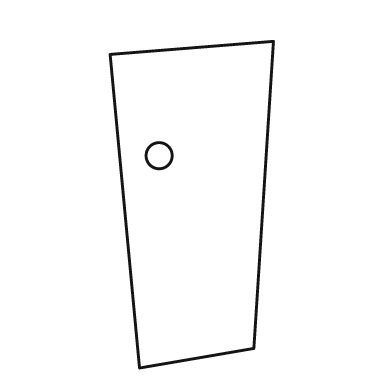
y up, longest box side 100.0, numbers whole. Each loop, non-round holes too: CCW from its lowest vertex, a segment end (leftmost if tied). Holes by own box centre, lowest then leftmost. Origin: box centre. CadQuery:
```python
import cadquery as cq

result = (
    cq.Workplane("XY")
    .moveTo(-16.0, -50.0)
    .lineTo(19.0, -44.0)
    .lineTo(25.0, 50.0)
    .lineTo(-25.0, 46.0)
    .close()
    .moveTo(-10.0, 15.0)
    .circle(4.0)
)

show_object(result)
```